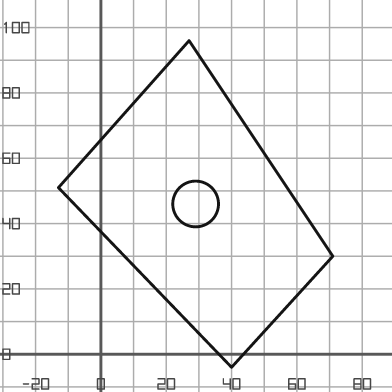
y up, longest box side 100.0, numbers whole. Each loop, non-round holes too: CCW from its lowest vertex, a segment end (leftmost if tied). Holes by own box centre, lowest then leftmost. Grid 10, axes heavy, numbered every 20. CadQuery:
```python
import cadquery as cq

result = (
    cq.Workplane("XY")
    .moveTo(40.0, -4.0)
    .lineTo(71.0, 30.0)
    .lineTo(27.0, 96.0)
    .lineTo(-13.0, 51.0)
    .close()
    .moveTo(29.0, 46.0)
    .circle(7.0)
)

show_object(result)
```